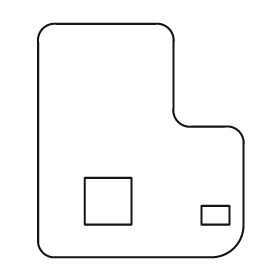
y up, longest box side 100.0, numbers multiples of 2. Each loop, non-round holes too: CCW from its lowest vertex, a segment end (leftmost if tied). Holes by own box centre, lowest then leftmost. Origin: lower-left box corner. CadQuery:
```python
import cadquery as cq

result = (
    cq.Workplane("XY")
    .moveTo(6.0, 0.0)
    .lineTo(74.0, 0.0)
    .threePointArc((84.0, 4.0), (88.0, 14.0))
    .lineTo(88.0, 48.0)
    .threePointArc((86.0, 54.0), (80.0, 56.0))
    .lineTo(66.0, 56.0)
    .threePointArc((60.0, 58.0), (58.0, 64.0))
    .lineTo(58.0, 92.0)
    .threePointArc((56.0, 98.0), (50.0, 100.0))
    .lineTo(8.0, 100.0)
    .threePointArc((2.0, 98.0), (0.0, 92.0))
    .lineTo(0.0, 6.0)
    .threePointArc((2.0, 2.0), (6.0, 0.0))
    .close()
    .moveTo(70.0, 14.0)
    .lineTo(82.0, 14.0)
    .lineTo(82.0, 22.0)
    .lineTo(70.0, 22.0)
    .close()
    .moveTo(20.0, 14.0)
    .lineTo(40.0, 14.0)
    .lineTo(40.0, 34.0)
    .lineTo(20.0, 34.0)
    .close()
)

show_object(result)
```